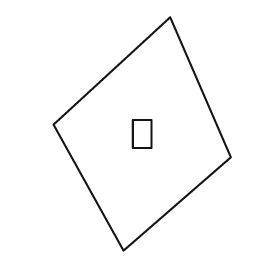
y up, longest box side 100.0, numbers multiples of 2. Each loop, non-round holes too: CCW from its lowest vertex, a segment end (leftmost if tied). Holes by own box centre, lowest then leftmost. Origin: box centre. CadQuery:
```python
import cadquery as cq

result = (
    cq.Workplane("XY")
    .moveTo(-8.0, -50.0)
    .lineTo(38.0, -10.0)
    .lineTo(12.0, 50.0)
    .lineTo(-38.0, 4.0)
    .close()
    .moveTo(-4.0, -6.0)
    .lineTo(4.0, -6.0)
    .lineTo(4.0, 6.0)
    .lineTo(-4.0, 6.0)
    .close()
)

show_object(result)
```